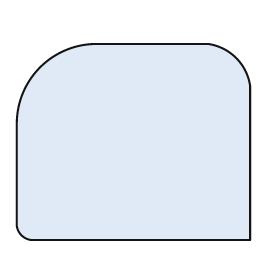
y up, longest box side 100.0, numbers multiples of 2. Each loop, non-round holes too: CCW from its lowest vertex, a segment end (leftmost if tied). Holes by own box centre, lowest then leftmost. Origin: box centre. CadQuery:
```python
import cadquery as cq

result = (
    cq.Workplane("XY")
    .moveTo(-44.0, -42.0)
    .lineTo(50.0, -42.0)
    .lineTo(50.0, 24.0)
    .threePointArc((44.0, 36.0), (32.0, 42.0))
    .lineTo(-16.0, 42.0)
    .threePointArc((-40.0, 32.0), (-50.0, 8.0))
    .lineTo(-50.0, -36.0)
    .threePointArc((-48.0, -40.0), (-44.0, -42.0))
    .close()
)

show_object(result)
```